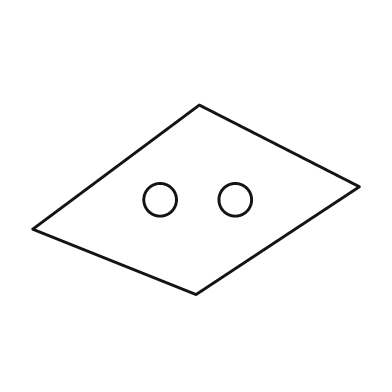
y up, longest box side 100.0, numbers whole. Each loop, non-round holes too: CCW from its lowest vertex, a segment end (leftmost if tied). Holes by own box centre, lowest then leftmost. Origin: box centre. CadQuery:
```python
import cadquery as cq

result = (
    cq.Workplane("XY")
    .moveTo(0.0, -29.0)
    .lineTo(50.0, 4.0)
    .lineTo(1.0, 29.0)
    .lineTo(-50.0, -9.0)
    .close()
    .moveTo(-11.0, 0.0)
    .circle(5.0)
    .moveTo(12.0, 0.0)
    .circle(5.0)
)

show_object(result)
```